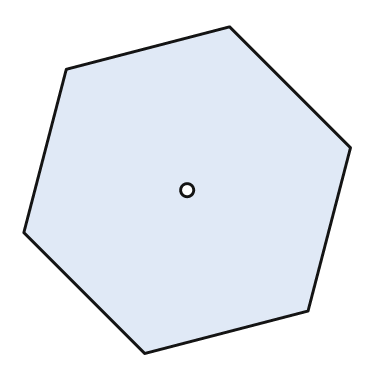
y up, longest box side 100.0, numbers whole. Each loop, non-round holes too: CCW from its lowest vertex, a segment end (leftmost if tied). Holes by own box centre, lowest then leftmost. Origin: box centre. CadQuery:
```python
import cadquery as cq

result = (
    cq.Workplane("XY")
    .moveTo(-13.0, -50.0)
    .lineTo(37.0, -37.0)
    .lineTo(50.0, 13.0)
    .lineTo(13.0, 50.0)
    .lineTo(-37.0, 37.0)
    .lineTo(-50.0, -13.0)
    .close()
    .moveTo(0.0, 0.0)
    .circle(2.0)
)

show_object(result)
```